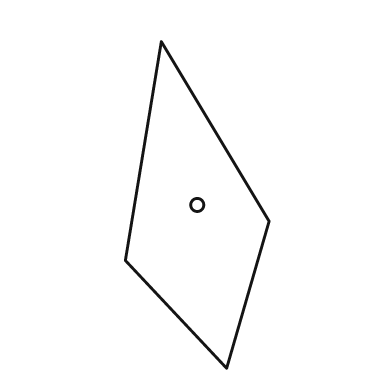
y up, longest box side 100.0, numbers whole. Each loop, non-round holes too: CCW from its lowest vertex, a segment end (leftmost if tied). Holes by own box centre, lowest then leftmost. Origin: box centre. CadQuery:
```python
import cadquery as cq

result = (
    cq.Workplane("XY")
    .moveTo(9.0, -50.0)
    .lineTo(22.0, -5.0)
    .lineTo(-11.0, 50.0)
    .lineTo(-22.0, -17.0)
    .close()
    .moveTo(0.0, 0.0)
    .circle(2.0)
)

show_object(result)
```